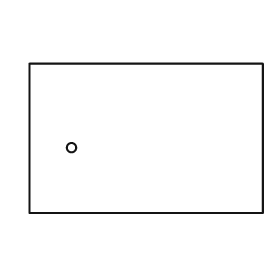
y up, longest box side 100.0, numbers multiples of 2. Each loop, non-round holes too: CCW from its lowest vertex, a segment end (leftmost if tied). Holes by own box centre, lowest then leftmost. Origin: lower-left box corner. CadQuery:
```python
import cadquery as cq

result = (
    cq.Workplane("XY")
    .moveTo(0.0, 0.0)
    .lineTo(100.0, 0.0)
    .lineTo(100.0, 64.0)
    .lineTo(0.0, 64.0)
    .close()
    .moveTo(18.0, 28.0)
    .circle(2.0)
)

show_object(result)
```